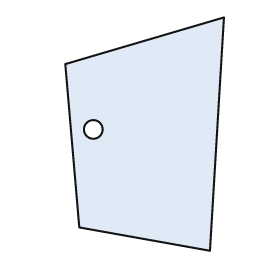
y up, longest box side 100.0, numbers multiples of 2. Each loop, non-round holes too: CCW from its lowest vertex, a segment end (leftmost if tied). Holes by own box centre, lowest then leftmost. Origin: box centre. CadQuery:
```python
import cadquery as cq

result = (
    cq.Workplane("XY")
    .moveTo(28.0, -50.0)
    .lineTo(34.0, 50.0)
    .lineTo(-34.0, 30.0)
    .lineTo(-28.0, -40.0)
    .close()
    .moveTo(-22.0, 2.0)
    .circle(4.0)
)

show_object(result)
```